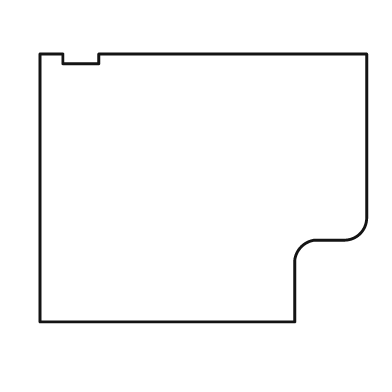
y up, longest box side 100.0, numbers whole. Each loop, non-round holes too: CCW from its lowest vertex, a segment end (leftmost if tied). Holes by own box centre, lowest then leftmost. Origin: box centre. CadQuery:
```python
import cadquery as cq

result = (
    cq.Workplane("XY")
    .moveTo(-50.0, -41.0)
    .lineTo(28.0, -41.0)
    .lineTo(28.0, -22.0)
    .threePointArc((30.0, -18.0), (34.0, -16.0))
    .lineTo(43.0, -16.0)
    .threePointArc((48.0, -14.0), (50.0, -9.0))
    .lineTo(50.0, 41.0)
    .lineTo(-32.0, 41.0)
    .lineTo(-32.0, 38.0)
    .lineTo(-43.0, 38.0)
    .lineTo(-43.0, 41.0)
    .lineTo(-50.0, 41.0)
    .close()
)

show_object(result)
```